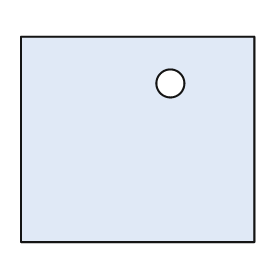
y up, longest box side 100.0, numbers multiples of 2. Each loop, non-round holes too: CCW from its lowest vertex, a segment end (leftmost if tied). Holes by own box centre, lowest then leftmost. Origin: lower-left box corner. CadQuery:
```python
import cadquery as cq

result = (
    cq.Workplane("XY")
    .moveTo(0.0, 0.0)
    .lineTo(100.0, 0.0)
    .lineTo(100.0, 88.0)
    .lineTo(0.0, 88.0)
    .close()
    .moveTo(64.0, 68.0)
    .circle(6.0)
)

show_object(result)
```